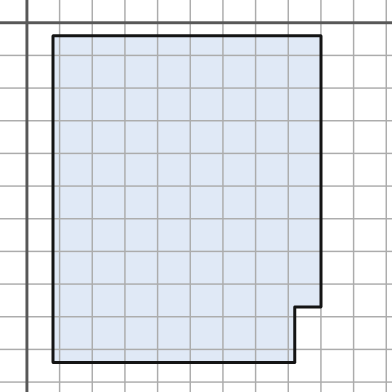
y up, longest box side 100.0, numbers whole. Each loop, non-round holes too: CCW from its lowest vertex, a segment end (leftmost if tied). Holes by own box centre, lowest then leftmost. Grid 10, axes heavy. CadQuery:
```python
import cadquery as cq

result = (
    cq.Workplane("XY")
    .moveTo(8.0, -104.0)
    .lineTo(82.0, -104.0)
    .lineTo(82.0, -87.0)
    .lineTo(90.0, -87.0)
    .lineTo(90.0, -4.0)
    .lineTo(8.0, -4.0)
    .close()
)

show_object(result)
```